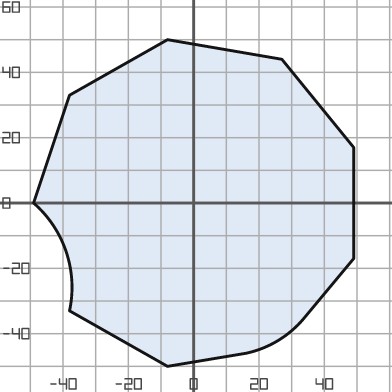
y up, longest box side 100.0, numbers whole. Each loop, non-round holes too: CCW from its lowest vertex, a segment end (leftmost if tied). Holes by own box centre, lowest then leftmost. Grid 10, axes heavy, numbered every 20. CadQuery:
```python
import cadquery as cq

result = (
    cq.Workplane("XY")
    .moveTo(-8.0, -50.0)
    .lineTo(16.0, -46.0)
    .threePointArc((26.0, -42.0), (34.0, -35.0))
    .lineTo(49.0, -17.0)
    .lineTo(49.0, 17.0)
    .lineTo(27.0, 44.0)
    .lineTo(-8.0, 50.0)
    .lineTo(-38.0, 33.0)
    .lineTo(-49.0, 0.0)
    .threePointArc((-39.0, -15.0), (-38.0, -33.0))
    .close()
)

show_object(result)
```